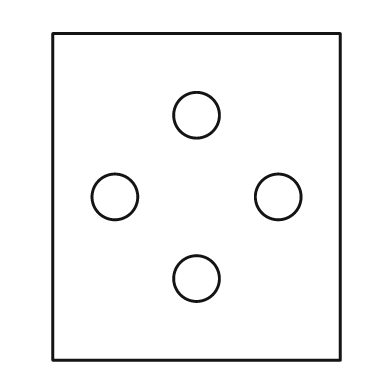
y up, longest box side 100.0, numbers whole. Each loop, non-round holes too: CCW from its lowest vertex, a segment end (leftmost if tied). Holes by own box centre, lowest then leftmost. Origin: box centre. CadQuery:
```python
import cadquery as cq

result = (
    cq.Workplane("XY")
    .moveTo(-44.0, -50.0)
    .lineTo(44.0, -50.0)
    .lineTo(44.0, 50.0)
    .lineTo(-44.0, 50.0)
    .close()
    .moveTo(0.0, -25.0)
    .circle(7.0)
    .moveTo(-25.0, 0.0)
    .circle(7.0)
    .moveTo(25.0, 0.0)
    .circle(7.0)
    .moveTo(0.0, 25.0)
    .circle(7.0)
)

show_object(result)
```